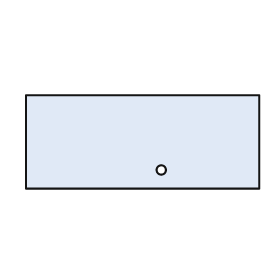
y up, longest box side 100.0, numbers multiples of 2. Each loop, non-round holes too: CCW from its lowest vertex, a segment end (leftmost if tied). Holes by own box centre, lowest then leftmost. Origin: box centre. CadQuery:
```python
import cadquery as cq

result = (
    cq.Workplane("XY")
    .moveTo(-50.0, -20.0)
    .lineTo(50.0, -20.0)
    .lineTo(50.0, 20.0)
    .lineTo(-50.0, 20.0)
    .close()
    .moveTo(8.0, -12.0)
    .circle(2.0)
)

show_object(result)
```